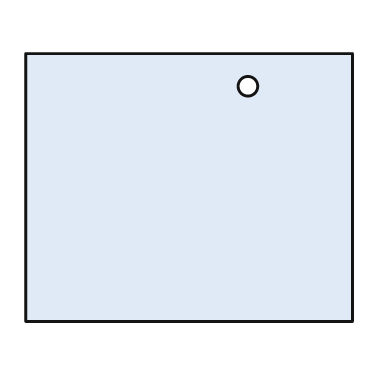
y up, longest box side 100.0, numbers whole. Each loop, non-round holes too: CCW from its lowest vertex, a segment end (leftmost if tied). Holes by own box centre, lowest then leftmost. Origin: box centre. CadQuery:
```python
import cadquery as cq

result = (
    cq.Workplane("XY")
    .moveTo(-50.0, -41.0)
    .lineTo(50.0, -41.0)
    .lineTo(50.0, 41.0)
    .lineTo(-50.0, 41.0)
    .close()
    .moveTo(18.0, 31.0)
    .circle(3.0)
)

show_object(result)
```